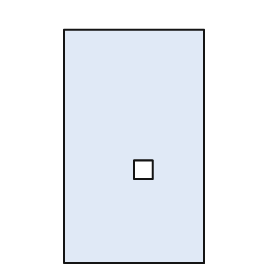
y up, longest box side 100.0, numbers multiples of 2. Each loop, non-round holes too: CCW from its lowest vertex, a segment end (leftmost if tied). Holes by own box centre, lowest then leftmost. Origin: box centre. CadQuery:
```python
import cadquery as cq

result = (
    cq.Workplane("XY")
    .moveTo(-30.0, -50.0)
    .lineTo(30.0, -50.0)
    .lineTo(30.0, 50.0)
    .lineTo(-30.0, 50.0)
    .close()
    .moveTo(0.0, -14.0)
    .lineTo(8.0, -14.0)
    .lineTo(8.0, -6.0)
    .lineTo(0.0, -6.0)
    .close()
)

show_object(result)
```